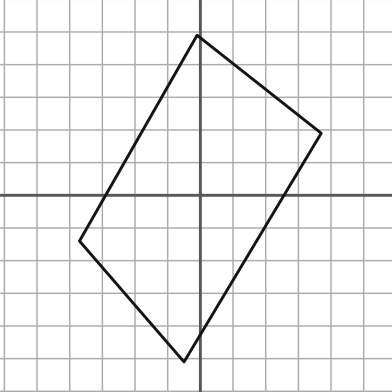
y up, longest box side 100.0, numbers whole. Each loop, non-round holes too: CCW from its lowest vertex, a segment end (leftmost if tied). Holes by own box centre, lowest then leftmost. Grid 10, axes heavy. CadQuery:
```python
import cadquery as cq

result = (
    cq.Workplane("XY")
    .moveTo(-5.0, -51.0)
    .lineTo(37.0, 19.0)
    .lineTo(-1.0, 49.0)
    .lineTo(-37.0, -14.0)
    .close()
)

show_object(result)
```